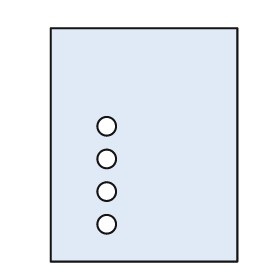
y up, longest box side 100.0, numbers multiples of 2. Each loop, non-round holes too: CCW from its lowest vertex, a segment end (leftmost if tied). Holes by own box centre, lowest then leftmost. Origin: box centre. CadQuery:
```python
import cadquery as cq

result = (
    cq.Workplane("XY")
    .moveTo(-40.0, -50.0)
    .lineTo(40.0, -50.0)
    .lineTo(40.0, 50.0)
    .lineTo(-40.0, 50.0)
    .close()
    .moveTo(-16.0, -34.0)
    .circle(4.0)
    .moveTo(-16.0, -20.0)
    .circle(4.0)
    .moveTo(-16.0, -6.0)
    .circle(4.0)
    .moveTo(-16.0, 8.0)
    .circle(4.0)
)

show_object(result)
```